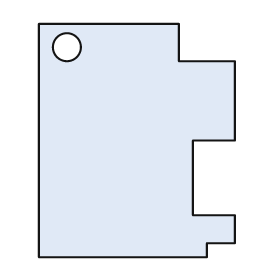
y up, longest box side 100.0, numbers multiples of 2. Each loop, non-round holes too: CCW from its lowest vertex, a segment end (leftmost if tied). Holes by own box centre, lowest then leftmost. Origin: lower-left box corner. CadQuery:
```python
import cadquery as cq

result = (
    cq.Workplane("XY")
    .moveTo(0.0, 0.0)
    .lineTo(72.0, 0.0)
    .lineTo(72.0, 6.0)
    .lineTo(84.0, 6.0)
    .lineTo(84.0, 18.0)
    .lineTo(66.0, 18.0)
    .lineTo(66.0, 50.0)
    .lineTo(84.0, 50.0)
    .lineTo(84.0, 84.0)
    .lineTo(60.0, 84.0)
    .lineTo(60.0, 100.0)
    .lineTo(0.0, 100.0)
    .close()
    .moveTo(12.0, 90.0)
    .circle(6.0)
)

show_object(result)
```